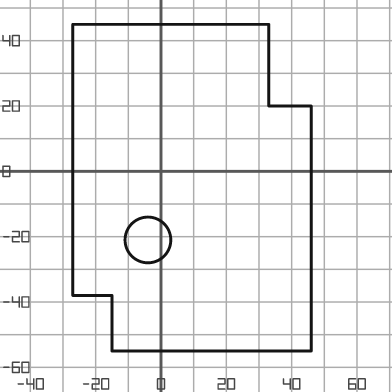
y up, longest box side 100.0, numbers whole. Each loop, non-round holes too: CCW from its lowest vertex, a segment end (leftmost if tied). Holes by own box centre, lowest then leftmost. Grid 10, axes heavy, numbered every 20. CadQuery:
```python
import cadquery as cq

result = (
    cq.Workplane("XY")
    .moveTo(-15.0, -55.0)
    .lineTo(46.0, -55.0)
    .lineTo(46.0, 20.0)
    .lineTo(33.0, 20.0)
    .lineTo(33.0, 45.0)
    .lineTo(-27.0, 45.0)
    .lineTo(-27.0, -38.0)
    .lineTo(-15.0, -38.0)
    .close()
    .moveTo(-4.0, -21.0)
    .circle(7.0)
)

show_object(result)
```